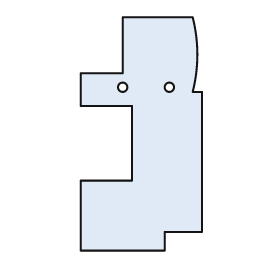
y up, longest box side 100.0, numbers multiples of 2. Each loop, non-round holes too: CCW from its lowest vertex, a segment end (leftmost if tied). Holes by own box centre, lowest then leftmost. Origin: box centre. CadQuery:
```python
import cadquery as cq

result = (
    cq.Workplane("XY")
    .moveTo(-26.0, -50.0)
    .lineTo(10.0, -50.0)
    .lineTo(10.0, -42.0)
    .lineTo(26.0, -42.0)
    .lineTo(26.0, 18.0)
    .lineTo(22.0, 18.0)
    .threePointArc((24.0, 34.0), (22.0, 50.0))
    .lineTo(-8.0, 50.0)
    .lineTo(-8.0, 26.0)
    .lineTo(-26.0, 26.0)
    .lineTo(-26.0, 12.0)
    .lineTo(-4.0, 12.0)
    .lineTo(-4.0, -20.0)
    .lineTo(-26.0, -20.0)
    .close()
    .moveTo(-8.0, 20.0)
    .circle(2.0)
    .moveTo(12.0, 20.0)
    .circle(2.0)
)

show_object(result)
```